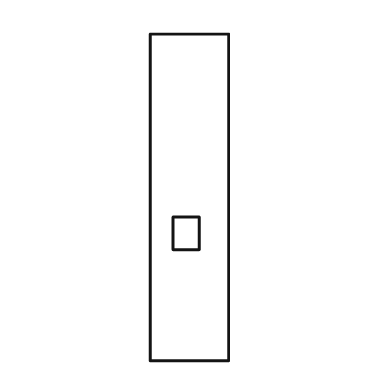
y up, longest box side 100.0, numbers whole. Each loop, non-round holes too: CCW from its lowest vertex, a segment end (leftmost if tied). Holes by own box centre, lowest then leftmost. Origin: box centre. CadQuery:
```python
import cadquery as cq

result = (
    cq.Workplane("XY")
    .moveTo(-12.0, -50.0)
    .lineTo(12.0, -50.0)
    .lineTo(12.0, 50.0)
    .lineTo(-12.0, 50.0)
    .close()
    .moveTo(-5.0, -16.0)
    .lineTo(3.0, -16.0)
    .lineTo(3.0, -6.0)
    .lineTo(-5.0, -6.0)
    .close()
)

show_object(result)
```